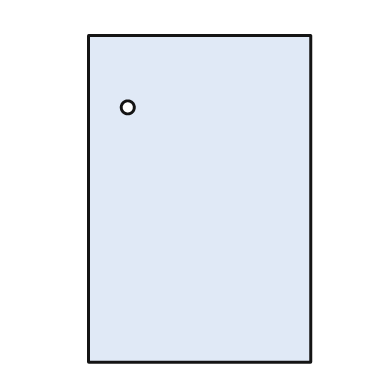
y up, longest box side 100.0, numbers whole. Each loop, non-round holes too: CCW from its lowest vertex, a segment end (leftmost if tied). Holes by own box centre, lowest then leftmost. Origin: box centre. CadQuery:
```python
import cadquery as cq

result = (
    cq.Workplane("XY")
    .moveTo(-34.0, -50.0)
    .lineTo(34.0, -50.0)
    .lineTo(34.0, 50.0)
    .lineTo(-34.0, 50.0)
    .close()
    .moveTo(-22.0, 28.0)
    .circle(2.0)
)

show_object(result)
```